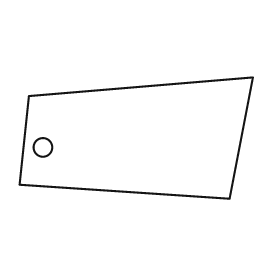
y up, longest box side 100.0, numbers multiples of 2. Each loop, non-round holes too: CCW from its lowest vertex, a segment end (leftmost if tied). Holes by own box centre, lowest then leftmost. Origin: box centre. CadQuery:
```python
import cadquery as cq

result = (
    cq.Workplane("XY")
    .moveTo(40.0, -26.0)
    .lineTo(50.0, 26.0)
    .lineTo(-46.0, 18.0)
    .lineTo(-50.0, -20.0)
    .close()
    .moveTo(-40.0, -4.0)
    .circle(4.0)
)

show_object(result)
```